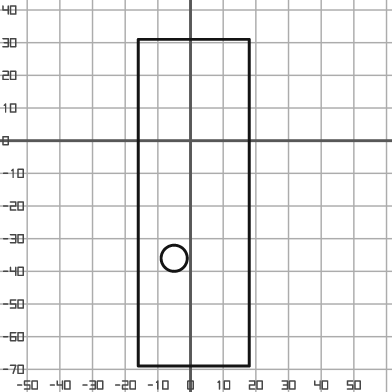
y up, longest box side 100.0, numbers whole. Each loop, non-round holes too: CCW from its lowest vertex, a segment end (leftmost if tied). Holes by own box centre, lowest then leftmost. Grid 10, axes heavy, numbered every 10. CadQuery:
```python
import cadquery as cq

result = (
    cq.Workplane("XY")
    .moveTo(-16.0, -69.0)
    .lineTo(18.0, -69.0)
    .lineTo(18.0, 31.0)
    .lineTo(-16.0, 31.0)
    .close()
    .moveTo(-5.0, -36.0)
    .circle(4.0)
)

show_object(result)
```